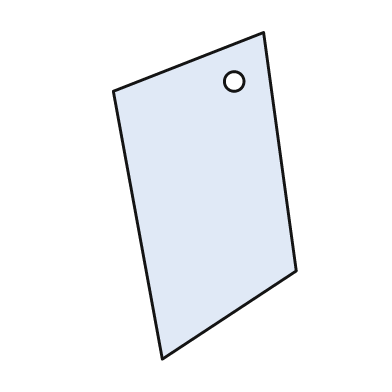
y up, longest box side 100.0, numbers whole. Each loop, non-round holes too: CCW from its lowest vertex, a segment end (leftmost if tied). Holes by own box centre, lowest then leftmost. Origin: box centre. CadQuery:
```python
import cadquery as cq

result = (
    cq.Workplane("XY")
    .moveTo(-13.0, -50.0)
    .lineTo(28.0, -23.0)
    .lineTo(18.0, 50.0)
    .lineTo(-28.0, 32.0)
    .close()
    .moveTo(9.0, 35.0)
    .circle(3.0)
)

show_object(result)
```